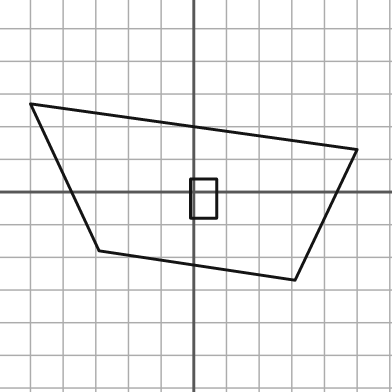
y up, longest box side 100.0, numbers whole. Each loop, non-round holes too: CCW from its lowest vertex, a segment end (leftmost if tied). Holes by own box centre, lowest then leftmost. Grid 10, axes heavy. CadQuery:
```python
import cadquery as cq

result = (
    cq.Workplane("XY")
    .moveTo(31.0, -27.0)
    .lineTo(50.0, 13.0)
    .lineTo(-50.0, 27.0)
    .lineTo(-29.0, -18.0)
    .close()
    .moveTo(-1.0, -8.0)
    .lineTo(7.0, -8.0)
    .lineTo(7.0, 4.0)
    .lineTo(-1.0, 4.0)
    .close()
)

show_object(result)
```